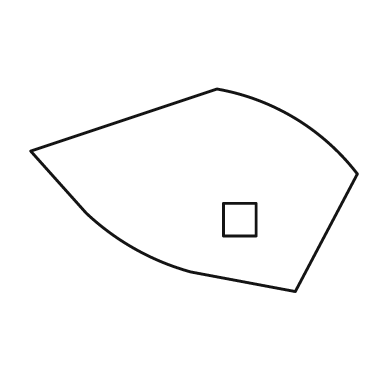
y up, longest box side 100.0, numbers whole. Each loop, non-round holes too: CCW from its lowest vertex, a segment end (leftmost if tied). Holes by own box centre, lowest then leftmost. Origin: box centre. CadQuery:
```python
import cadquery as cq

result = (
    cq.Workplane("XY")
    .moveTo(31.0, -31.0)
    .lineTo(50.0, 5.0)
    .threePointArc((31.0, 22.0), (7.0, 31.0))
    .lineTo(-50.0, 12.0)
    .lineTo(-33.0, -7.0)
    .threePointArc((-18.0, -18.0), (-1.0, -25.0))
    .close()
    .moveTo(9.0, -14.0)
    .lineTo(19.0, -14.0)
    .lineTo(19.0, -4.0)
    .lineTo(9.0, -4.0)
    .close()
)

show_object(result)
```